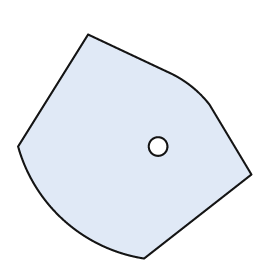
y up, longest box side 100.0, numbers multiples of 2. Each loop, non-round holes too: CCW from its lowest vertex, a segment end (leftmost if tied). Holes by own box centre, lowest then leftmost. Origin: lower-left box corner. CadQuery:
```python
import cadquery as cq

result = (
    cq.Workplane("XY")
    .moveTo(54.0, 0.0)
    .lineTo(100.0, 36.0)
    .lineTo(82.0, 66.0)
    .threePointArc((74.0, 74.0), (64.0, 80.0))
    .lineTo(30.0, 96.0)
    .lineTo(0.0, 48.0)
    .threePointArc((20.0, 16.0), (54.0, 0.0))
    .close()
    .moveTo(60.0, 48.0)
    .circle(4.0)
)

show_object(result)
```